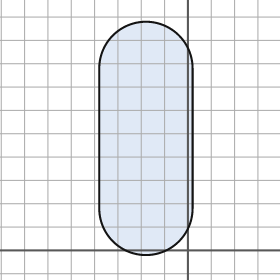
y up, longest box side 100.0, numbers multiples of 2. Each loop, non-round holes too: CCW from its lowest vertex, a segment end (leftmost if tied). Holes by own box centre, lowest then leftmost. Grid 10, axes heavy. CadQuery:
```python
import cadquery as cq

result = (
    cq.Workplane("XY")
    .moveTo(-38.0, 18.0)
    .threePointArc((-18.0, -2.0), (2.0, 18.0))
    .lineTo(2.0, 78.0)
    .threePointArc((-18.0, 98.0), (-38.0, 78.0))
    .close()
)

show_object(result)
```